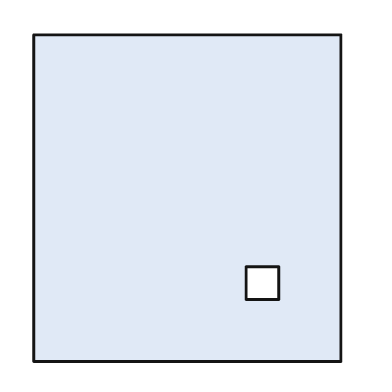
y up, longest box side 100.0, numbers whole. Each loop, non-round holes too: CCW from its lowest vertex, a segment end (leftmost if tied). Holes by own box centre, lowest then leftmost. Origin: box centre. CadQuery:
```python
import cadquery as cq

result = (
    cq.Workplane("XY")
    .moveTo(-47.0, -50.0)
    .lineTo(47.0, -50.0)
    .lineTo(47.0, 50.0)
    .lineTo(-47.0, 50.0)
    .close()
    .moveTo(18.0, -31.0)
    .lineTo(28.0, -31.0)
    .lineTo(28.0, -21.0)
    .lineTo(18.0, -21.0)
    .close()
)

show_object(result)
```